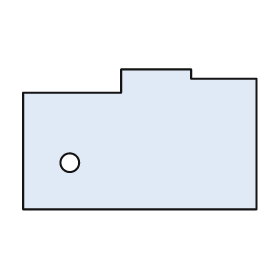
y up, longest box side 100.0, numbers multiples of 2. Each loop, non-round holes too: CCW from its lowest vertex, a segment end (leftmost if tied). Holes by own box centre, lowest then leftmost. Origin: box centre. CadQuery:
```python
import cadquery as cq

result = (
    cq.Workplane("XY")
    .moveTo(-50.0, -30.0)
    .lineTo(50.0, -30.0)
    .lineTo(50.0, 26.0)
    .lineTo(22.0, 26.0)
    .lineTo(22.0, 30.0)
    .lineTo(-8.0, 30.0)
    .lineTo(-8.0, 20.0)
    .lineTo(-50.0, 20.0)
    .close()
    .moveTo(-30.0, -10.0)
    .circle(4.0)
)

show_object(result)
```